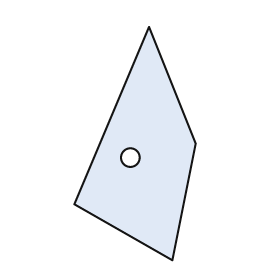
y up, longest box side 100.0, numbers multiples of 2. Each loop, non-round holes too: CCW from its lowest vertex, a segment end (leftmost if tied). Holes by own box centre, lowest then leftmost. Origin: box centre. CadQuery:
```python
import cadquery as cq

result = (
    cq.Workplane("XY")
    .moveTo(16.0, -50.0)
    .lineTo(26.0, 0.0)
    .lineTo(6.0, 50.0)
    .lineTo(-26.0, -26.0)
    .close()
    .moveTo(-2.0, -6.0)
    .circle(4.0)
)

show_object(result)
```